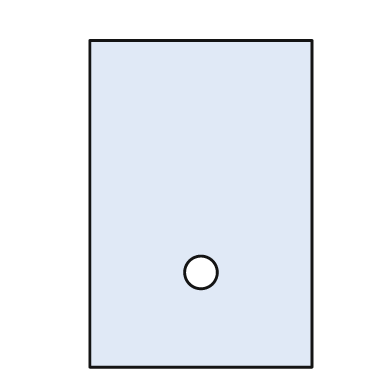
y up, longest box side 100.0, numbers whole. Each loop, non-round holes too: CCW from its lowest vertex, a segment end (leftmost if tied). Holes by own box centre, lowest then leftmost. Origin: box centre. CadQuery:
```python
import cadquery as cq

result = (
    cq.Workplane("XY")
    .moveTo(-34.0, -50.0)
    .lineTo(34.0, -50.0)
    .lineTo(34.0, 50.0)
    .lineTo(-34.0, 50.0)
    .close()
    .moveTo(0.0, -21.0)
    .circle(5.0)
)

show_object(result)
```